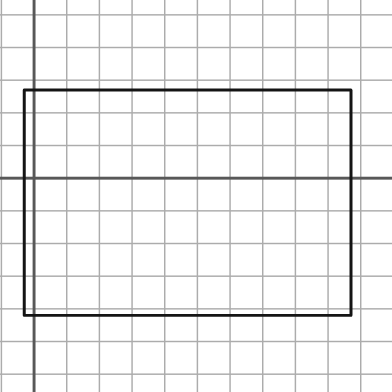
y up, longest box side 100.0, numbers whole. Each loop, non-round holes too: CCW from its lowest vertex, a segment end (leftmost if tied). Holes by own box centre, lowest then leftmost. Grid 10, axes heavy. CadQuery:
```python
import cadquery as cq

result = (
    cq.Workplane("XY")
    .moveTo(-3.0, -42.0)
    .lineTo(97.0, -42.0)
    .lineTo(97.0, 27.0)
    .lineTo(-3.0, 27.0)
    .close()
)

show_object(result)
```